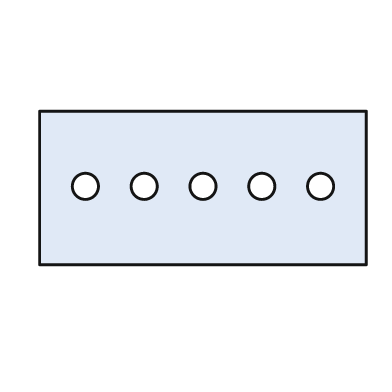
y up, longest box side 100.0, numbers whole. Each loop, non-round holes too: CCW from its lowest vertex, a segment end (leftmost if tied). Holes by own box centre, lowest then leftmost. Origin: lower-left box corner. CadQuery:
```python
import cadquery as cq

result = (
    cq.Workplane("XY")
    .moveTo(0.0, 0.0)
    .lineTo(100.0, 0.0)
    .lineTo(100.0, 47.0)
    .lineTo(0.0, 47.0)
    .close()
    .moveTo(14.0, 24.0)
    .circle(4.0)
    .moveTo(32.0, 24.0)
    .circle(4.0)
    .moveTo(50.0, 24.0)
    .circle(4.0)
    .moveTo(68.0, 24.0)
    .circle(4.0)
    .moveTo(86.0, 24.0)
    .circle(4.0)
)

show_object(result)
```